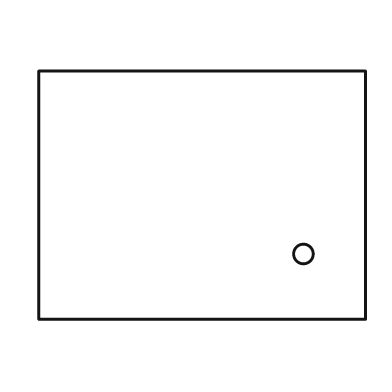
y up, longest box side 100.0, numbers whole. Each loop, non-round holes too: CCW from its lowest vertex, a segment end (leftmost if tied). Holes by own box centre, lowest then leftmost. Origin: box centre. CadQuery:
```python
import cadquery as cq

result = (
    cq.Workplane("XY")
    .moveTo(-50.0, -38.0)
    .lineTo(50.0, -38.0)
    .lineTo(50.0, 38.0)
    .lineTo(-50.0, 38.0)
    .close()
    .moveTo(31.0, -18.0)
    .circle(3.0)
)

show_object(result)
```